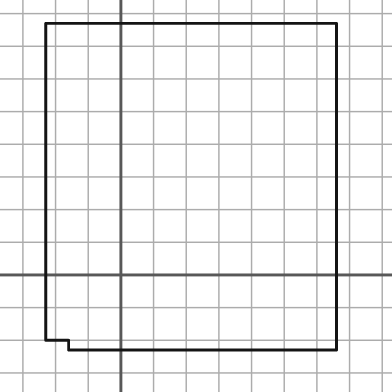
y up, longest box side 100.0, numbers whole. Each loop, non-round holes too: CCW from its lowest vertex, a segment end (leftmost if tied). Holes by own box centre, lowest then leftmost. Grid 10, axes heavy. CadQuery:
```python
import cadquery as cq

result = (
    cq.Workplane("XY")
    .moveTo(-16.0, -23.0)
    .lineTo(66.0, -23.0)
    .lineTo(66.0, 77.0)
    .lineTo(-23.0, 77.0)
    .lineTo(-23.0, -20.0)
    .lineTo(-16.0, -20.0)
    .close()
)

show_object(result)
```